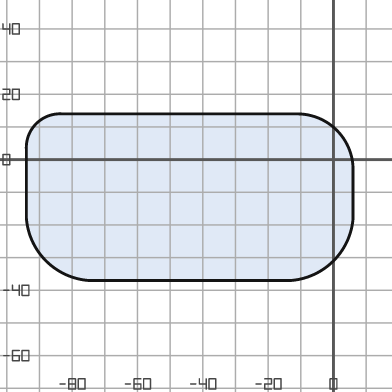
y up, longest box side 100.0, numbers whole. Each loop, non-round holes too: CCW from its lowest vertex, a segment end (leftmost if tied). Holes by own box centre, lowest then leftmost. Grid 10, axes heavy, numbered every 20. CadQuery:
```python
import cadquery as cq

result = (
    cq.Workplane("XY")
    .moveTo(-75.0, -37.0)
    .lineTo(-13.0, -37.0)
    .threePointArc((0.0, -31.0), (6.0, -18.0))
    .lineTo(6.0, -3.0)
    .threePointArc((1.0, 9.0), (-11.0, 14.0))
    .lineTo(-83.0, 14.0)
    .threePointArc((-91.0, 11.0), (-94.0, 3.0))
    .lineTo(-94.0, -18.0)
    .threePointArc((-88.0, -31.0), (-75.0, -37.0))
    .close()
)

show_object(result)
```